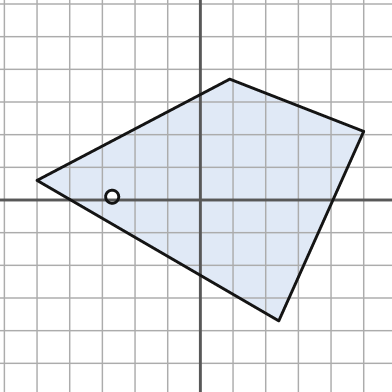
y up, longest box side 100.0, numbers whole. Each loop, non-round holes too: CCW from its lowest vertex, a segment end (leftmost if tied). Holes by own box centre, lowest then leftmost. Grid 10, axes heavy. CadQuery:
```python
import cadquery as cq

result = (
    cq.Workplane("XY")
    .moveTo(24.0, -37.0)
    .lineTo(50.0, 21.0)
    .lineTo(9.0, 37.0)
    .lineTo(-50.0, 6.0)
    .close()
    .moveTo(-27.0, 1.0)
    .circle(2.0)
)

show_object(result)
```